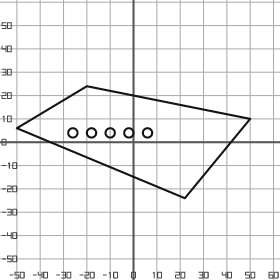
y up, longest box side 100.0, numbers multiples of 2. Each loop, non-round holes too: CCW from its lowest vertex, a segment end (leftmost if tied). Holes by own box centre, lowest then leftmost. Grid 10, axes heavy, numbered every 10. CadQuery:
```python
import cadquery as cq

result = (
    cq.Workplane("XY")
    .moveTo(22.0, -24.0)
    .lineTo(50.0, 10.0)
    .lineTo(-20.0, 24.0)
    .lineTo(-50.0, 6.0)
    .close()
    .moveTo(-26.0, 4.0)
    .circle(2.0)
    .moveTo(-18.0, 4.0)
    .circle(2.0)
    .moveTo(-10.0, 4.0)
    .circle(2.0)
    .moveTo(-2.0, 4.0)
    .circle(2.0)
    .moveTo(6.0, 4.0)
    .circle(2.0)
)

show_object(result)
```